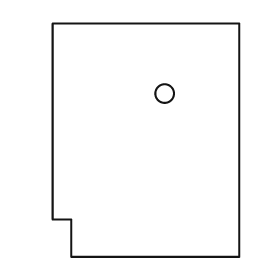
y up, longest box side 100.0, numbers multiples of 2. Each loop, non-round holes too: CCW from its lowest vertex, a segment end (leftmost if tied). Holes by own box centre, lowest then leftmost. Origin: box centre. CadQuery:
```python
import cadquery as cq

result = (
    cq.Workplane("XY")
    .moveTo(-32.0, -50.0)
    .lineTo(40.0, -50.0)
    .lineTo(40.0, 50.0)
    .lineTo(-40.0, 50.0)
    .lineTo(-40.0, -34.0)
    .lineTo(-32.0, -34.0)
    .close()
    .moveTo(8.0, 20.0)
    .circle(4.0)
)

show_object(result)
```